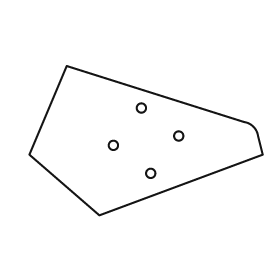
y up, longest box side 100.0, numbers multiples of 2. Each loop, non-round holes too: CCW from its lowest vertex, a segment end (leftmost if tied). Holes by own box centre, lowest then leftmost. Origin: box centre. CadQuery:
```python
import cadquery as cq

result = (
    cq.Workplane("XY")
    .moveTo(-20.0, -32.0)
    .lineTo(50.0, -6.0)
    .lineTo(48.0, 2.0)
    .threePointArc((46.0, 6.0), (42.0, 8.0))
    .lineTo(-34.0, 32.0)
    .lineTo(-50.0, -6.0)
    .close()
    .moveTo(2.0, -14.0)
    .circle(2.0)
    .moveTo(-14.0, -2.0)
    .circle(2.0)
    .moveTo(14.0, 2.0)
    .circle(2.0)
    .moveTo(-2.0, 14.0)
    .circle(2.0)
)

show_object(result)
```